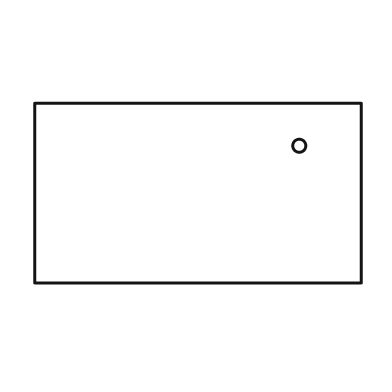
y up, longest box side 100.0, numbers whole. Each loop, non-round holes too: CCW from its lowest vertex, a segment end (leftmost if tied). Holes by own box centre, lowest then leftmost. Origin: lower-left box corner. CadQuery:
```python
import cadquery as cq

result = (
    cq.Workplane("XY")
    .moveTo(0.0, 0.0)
    .lineTo(100.0, 0.0)
    .lineTo(100.0, 55.0)
    .lineTo(0.0, 55.0)
    .close()
    .moveTo(81.0, 42.0)
    .circle(2.0)
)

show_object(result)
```